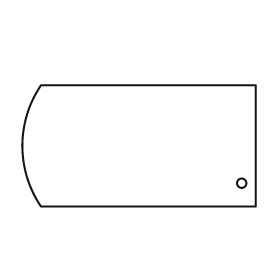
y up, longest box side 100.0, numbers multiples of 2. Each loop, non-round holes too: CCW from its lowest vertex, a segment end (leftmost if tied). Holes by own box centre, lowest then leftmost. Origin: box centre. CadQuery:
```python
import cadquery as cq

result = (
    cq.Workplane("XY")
    .moveTo(-42.0, -26.0)
    .lineTo(50.0, -26.0)
    .lineTo(50.0, 26.0)
    .lineTo(-42.0, 26.0)
    .threePointArc((-50.0, 0.0), (-42.0, -26.0))
    .close()
    .moveTo(44.0, -16.0)
    .circle(2.0)
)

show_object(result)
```